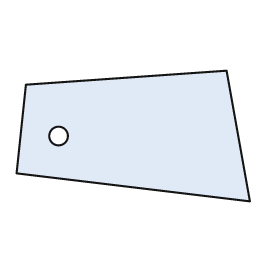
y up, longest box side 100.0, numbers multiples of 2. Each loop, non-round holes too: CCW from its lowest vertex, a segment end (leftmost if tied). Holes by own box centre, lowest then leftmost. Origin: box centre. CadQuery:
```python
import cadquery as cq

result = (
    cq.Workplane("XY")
    .moveTo(50.0, -28.0)
    .lineTo(40.0, 28.0)
    .lineTo(-46.0, 22.0)
    .lineTo(-50.0, -16.0)
    .close()
    .moveTo(-32.0, 0.0)
    .circle(4.0)
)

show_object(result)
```